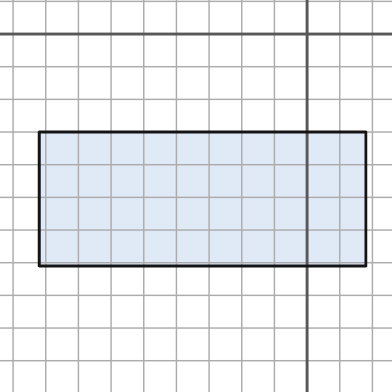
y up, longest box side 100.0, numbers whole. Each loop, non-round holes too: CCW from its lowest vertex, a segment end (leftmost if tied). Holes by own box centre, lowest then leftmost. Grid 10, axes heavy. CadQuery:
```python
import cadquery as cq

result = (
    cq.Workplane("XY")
    .moveTo(-82.0, -71.0)
    .lineTo(18.0, -71.0)
    .lineTo(18.0, -30.0)
    .lineTo(-82.0, -30.0)
    .close()
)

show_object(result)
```